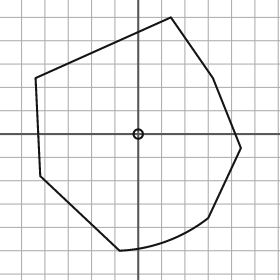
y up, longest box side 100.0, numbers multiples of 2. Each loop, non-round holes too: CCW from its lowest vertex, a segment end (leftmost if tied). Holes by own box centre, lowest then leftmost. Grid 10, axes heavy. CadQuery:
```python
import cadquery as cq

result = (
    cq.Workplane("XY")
    .moveTo(-8.0, -50.0)
    .threePointArc((12.0, -46.0), (30.0, -36.0))
    .lineTo(44.0, -6.0)
    .lineTo(32.0, 24.0)
    .lineTo(14.0, 50.0)
    .lineTo(-44.0, 24.0)
    .lineTo(-42.0, -18.0)
    .close()
    .moveTo(0.0, 0.0)
    .circle(2.0)
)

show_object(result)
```